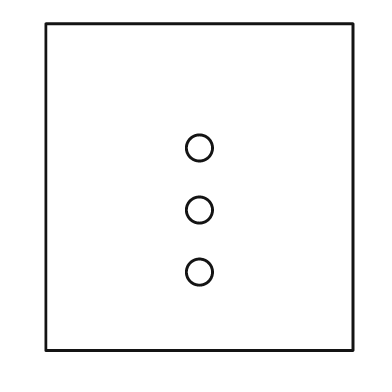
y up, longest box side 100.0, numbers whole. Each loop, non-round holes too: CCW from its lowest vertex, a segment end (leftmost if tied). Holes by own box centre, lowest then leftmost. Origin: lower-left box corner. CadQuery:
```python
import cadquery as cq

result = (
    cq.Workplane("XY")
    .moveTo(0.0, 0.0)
    .lineTo(94.0, 0.0)
    .lineTo(94.0, 100.0)
    .lineTo(0.0, 100.0)
    .close()
    .moveTo(47.0, 24.0)
    .circle(4.0)
    .moveTo(47.0, 43.0)
    .circle(4.0)
    .moveTo(47.0, 62.0)
    .circle(4.0)
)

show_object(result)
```